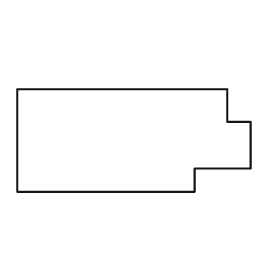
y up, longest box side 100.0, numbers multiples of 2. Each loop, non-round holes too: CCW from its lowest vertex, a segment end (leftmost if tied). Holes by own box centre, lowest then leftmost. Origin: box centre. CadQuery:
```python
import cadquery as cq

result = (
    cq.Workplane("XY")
    .moveTo(-50.0, -22.0)
    .lineTo(26.0, -22.0)
    .lineTo(26.0, -12.0)
    .lineTo(50.0, -12.0)
    .lineTo(50.0, 8.0)
    .lineTo(40.0, 8.0)
    .lineTo(40.0, 22.0)
    .lineTo(-50.0, 22.0)
    .close()
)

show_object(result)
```